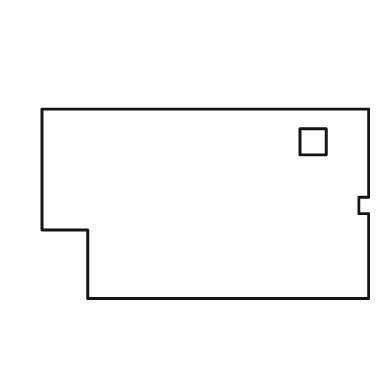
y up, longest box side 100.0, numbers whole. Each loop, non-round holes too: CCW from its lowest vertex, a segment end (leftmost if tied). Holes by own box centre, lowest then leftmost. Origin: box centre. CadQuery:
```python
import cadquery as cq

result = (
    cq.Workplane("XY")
    .moveTo(-36.0, -29.0)
    .lineTo(50.0, -29.0)
    .lineTo(50.0, -3.0)
    .lineTo(47.0, -3.0)
    .lineTo(47.0, 2.0)
    .lineTo(50.0, 2.0)
    .lineTo(50.0, 29.0)
    .lineTo(-50.0, 29.0)
    .lineTo(-50.0, -8.0)
    .lineTo(-36.0, -8.0)
    .close()
    .moveTo(29.0, 15.0)
    .lineTo(37.0, 15.0)
    .lineTo(37.0, 23.0)
    .lineTo(29.0, 23.0)
    .close()
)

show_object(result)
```